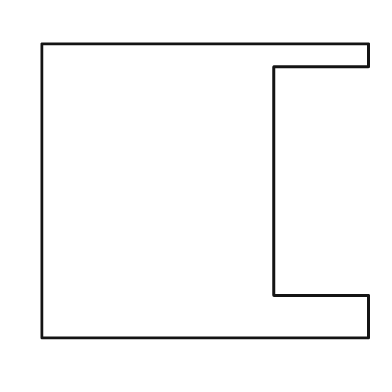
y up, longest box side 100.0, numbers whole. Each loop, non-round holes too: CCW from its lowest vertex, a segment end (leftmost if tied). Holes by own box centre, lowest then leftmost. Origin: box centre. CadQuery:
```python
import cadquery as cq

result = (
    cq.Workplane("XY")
    .moveTo(-50.0, -45.0)
    .lineTo(50.0, -45.0)
    .lineTo(50.0, -32.0)
    .lineTo(21.0, -32.0)
    .lineTo(21.0, 38.0)
    .lineTo(50.0, 38.0)
    .lineTo(50.0, 45.0)
    .lineTo(-50.0, 45.0)
    .close()
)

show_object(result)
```